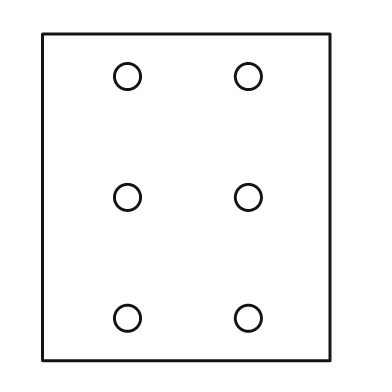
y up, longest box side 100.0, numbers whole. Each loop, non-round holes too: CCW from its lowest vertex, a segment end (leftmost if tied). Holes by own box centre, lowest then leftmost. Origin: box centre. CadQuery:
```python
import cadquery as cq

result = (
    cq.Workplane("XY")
    .moveTo(-44.0, -50.0)
    .lineTo(44.0, -50.0)
    .lineTo(44.0, 50.0)
    .lineTo(-44.0, 50.0)
    .close()
    .moveTo(-18.0, -37.0)
    .circle(4.0)
    .moveTo(19.0, -37.0)
    .circle(4.0)
    .moveTo(-18.0, 0.0)
    .circle(4.0)
    .moveTo(19.0, 0.0)
    .circle(4.0)
    .moveTo(-18.0, 37.0)
    .circle(4.0)
    .moveTo(19.0, 37.0)
    .circle(4.0)
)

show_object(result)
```